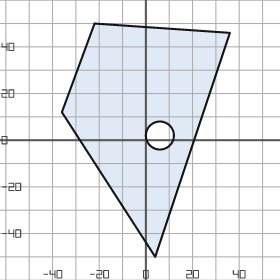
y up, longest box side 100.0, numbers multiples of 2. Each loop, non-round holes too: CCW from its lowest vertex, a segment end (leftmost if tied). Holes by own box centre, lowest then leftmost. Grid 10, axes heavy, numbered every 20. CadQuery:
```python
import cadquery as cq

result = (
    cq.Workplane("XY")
    .moveTo(4.0, -50.0)
    .lineTo(36.0, 46.0)
    .lineTo(-22.0, 50.0)
    .lineTo(-36.0, 12.0)
    .close()
    .moveTo(6.0, 2.0)
    .circle(6.0)
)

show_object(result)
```